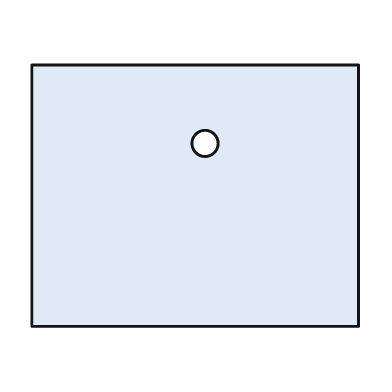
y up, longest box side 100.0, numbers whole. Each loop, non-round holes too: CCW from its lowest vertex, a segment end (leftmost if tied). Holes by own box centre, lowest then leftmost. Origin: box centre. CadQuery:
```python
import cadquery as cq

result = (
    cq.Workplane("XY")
    .moveTo(-50.0, -40.0)
    .lineTo(50.0, -40.0)
    .lineTo(50.0, 40.0)
    .lineTo(-50.0, 40.0)
    .close()
    .moveTo(3.0, 16.0)
    .circle(4.0)
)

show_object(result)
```